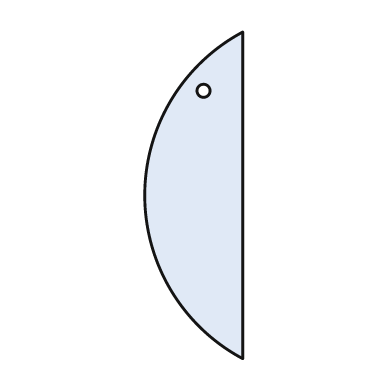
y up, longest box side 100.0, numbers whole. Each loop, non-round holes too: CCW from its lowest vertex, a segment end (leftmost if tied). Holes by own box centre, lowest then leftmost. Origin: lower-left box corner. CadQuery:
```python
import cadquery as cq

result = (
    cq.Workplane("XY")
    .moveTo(30.0, 0.0)
    .lineTo(30.0, 100.0)
    .threePointArc((0.0, 50.0), (30.0, 0.0))
    .close()
    .moveTo(18.0, 82.0)
    .circle(2.0)
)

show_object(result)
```